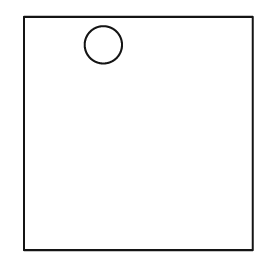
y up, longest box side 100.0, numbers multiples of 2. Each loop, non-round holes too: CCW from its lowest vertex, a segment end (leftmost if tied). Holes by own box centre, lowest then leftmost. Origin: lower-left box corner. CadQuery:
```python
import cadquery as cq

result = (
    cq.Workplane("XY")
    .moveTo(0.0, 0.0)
    .lineTo(98.0, 0.0)
    .lineTo(98.0, 100.0)
    .lineTo(0.0, 100.0)
    .close()
    .moveTo(34.0, 88.0)
    .circle(8.0)
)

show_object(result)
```